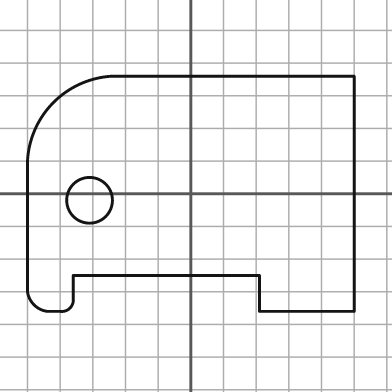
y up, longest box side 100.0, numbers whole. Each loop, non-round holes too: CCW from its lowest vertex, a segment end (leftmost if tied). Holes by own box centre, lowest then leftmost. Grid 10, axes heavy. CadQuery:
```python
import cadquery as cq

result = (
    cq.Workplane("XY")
    .moveTo(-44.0, -36.0)
    .lineTo(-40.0, -36.0)
    .threePointArc((-37.0, -35.0), (-36.0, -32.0))
    .lineTo(-36.0, -25.0)
    .lineTo(21.0, -25.0)
    .lineTo(21.0, -36.0)
    .lineTo(50.0, -36.0)
    .lineTo(50.0, 36.0)
    .lineTo(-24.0, 36.0)
    .threePointArc((-42.0, 28.0), (-50.0, 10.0))
    .lineTo(-50.0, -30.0)
    .threePointArc((-48.0, -34.0), (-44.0, -36.0))
    .close()
    .moveTo(-31.0, -2.0)
    .circle(7.0)
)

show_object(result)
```